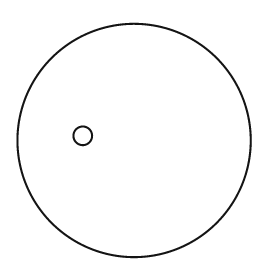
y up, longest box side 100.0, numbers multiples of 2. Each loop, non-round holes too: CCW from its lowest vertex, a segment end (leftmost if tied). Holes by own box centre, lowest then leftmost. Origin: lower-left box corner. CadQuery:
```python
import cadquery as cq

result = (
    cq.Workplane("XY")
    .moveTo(50.0, 50.0)
    .circle(50.0)
    .moveTo(28.0, 52.0)
    .circle(4.0)
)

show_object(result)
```